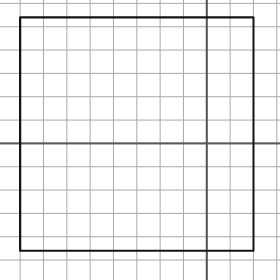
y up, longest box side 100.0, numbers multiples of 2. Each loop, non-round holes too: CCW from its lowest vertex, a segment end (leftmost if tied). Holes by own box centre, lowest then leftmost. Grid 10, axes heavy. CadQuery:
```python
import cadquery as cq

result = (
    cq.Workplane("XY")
    .moveTo(-80.0, -46.0)
    .lineTo(20.0, -46.0)
    .lineTo(20.0, 54.0)
    .lineTo(-80.0, 54.0)
    .close()
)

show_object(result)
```